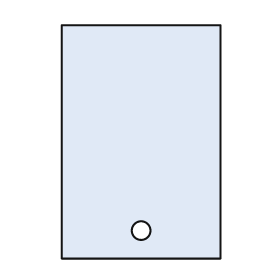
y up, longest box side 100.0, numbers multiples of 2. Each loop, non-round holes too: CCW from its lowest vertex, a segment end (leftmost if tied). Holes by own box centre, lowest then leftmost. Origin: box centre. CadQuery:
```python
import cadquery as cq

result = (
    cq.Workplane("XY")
    .moveTo(-34.0, -50.0)
    .lineTo(34.0, -50.0)
    .lineTo(34.0, 50.0)
    .lineTo(-34.0, 50.0)
    .close()
    .moveTo(0.0, -38.0)
    .circle(4.0)
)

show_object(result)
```